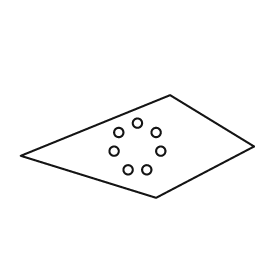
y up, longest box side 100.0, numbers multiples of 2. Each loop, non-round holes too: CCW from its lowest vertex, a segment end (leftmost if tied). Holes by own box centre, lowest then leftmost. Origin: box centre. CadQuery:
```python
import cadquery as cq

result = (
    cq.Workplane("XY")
    .moveTo(8.0, -22.0)
    .lineTo(50.0, 0.0)
    .lineTo(14.0, 22.0)
    .lineTo(-50.0, -4.0)
    .close()
    .moveTo(-4.0, -10.0)
    .circle(2.0)
    .moveTo(4.0, -10.0)
    .circle(2.0)
    .moveTo(-10.0, -2.0)
    .circle(2.0)
    .moveTo(10.0, -2.0)
    .circle(2.0)
    .moveTo(-8.0, 6.0)
    .circle(2.0)
    .moveTo(8.0, 6.0)
    .circle(2.0)
    .moveTo(0.0, 10.0)
    .circle(2.0)
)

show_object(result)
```